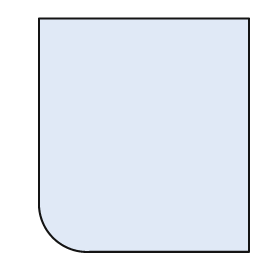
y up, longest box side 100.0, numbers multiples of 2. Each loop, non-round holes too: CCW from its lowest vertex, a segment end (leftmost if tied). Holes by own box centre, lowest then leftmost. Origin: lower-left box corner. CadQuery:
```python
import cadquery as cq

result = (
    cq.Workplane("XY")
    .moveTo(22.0, 0.0)
    .lineTo(90.0, 0.0)
    .lineTo(90.0, 100.0)
    .lineTo(0.0, 100.0)
    .lineTo(0.0, 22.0)
    .threePointArc((6.0, 6.0), (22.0, 0.0))
    .close()
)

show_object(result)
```